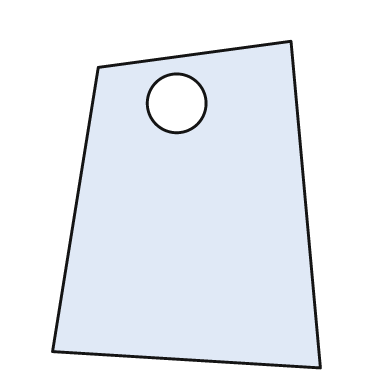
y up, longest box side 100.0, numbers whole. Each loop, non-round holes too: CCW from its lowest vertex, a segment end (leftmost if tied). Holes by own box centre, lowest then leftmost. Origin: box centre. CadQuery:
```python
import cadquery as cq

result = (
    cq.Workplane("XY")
    .moveTo(41.0, -50.0)
    .lineTo(32.0, 50.0)
    .lineTo(-27.0, 42.0)
    .lineTo(-41.0, -45.0)
    .close()
    .moveTo(-3.0, 31.0)
    .circle(9.0)
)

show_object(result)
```